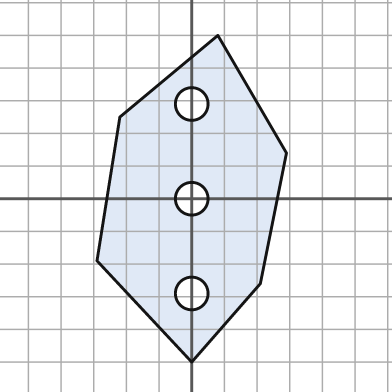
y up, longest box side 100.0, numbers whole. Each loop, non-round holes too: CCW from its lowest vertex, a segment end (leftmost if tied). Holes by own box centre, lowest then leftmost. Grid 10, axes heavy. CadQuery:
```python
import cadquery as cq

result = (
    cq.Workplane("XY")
    .moveTo(0.0, -50.0)
    .lineTo(21.0, -26.0)
    .lineTo(29.0, 14.0)
    .lineTo(8.0, 50.0)
    .lineTo(-22.0, 25.0)
    .lineTo(-29.0, -19.0)
    .close()
    .moveTo(0.0, -29.0)
    .circle(5.0)
    .moveTo(0.0, 0.0)
    .circle(5.0)
    .moveTo(0.0, 29.0)
    .circle(5.0)
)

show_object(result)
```